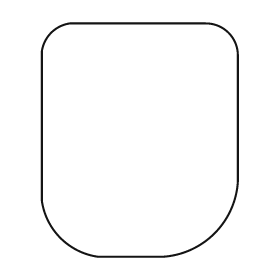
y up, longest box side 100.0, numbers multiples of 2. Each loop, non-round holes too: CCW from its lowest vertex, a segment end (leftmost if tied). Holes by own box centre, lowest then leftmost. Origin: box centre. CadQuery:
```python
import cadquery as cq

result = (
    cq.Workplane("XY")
    .moveTo(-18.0, -50.0)
    .lineTo(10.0, -50.0)
    .threePointArc((32.0, -40.0), (42.0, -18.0))
    .lineTo(42.0, 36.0)
    .threePointArc((38.0, 46.0), (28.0, 50.0))
    .lineTo(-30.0, 50.0)
    .threePointArc((-38.0, 46.0), (-42.0, 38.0))
    .lineTo(-42.0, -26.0)
    .threePointArc((-34.0, -42.0), (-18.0, -50.0))
    .close()
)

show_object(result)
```